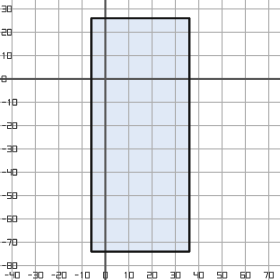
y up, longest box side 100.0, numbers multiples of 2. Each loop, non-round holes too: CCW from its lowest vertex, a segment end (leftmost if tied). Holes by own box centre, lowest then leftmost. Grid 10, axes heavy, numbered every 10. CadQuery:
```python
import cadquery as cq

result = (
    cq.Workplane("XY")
    .moveTo(-6.0, -74.0)
    .lineTo(36.0, -74.0)
    .lineTo(36.0, 26.0)
    .lineTo(-6.0, 26.0)
    .close()
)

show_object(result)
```